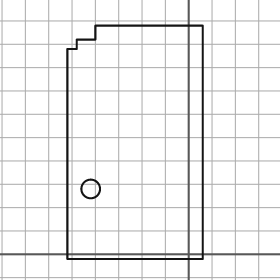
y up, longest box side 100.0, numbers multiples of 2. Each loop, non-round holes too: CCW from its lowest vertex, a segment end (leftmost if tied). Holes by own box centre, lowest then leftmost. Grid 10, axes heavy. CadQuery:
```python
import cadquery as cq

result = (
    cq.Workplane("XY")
    .moveTo(-52.0, -2.0)
    .lineTo(6.0, -2.0)
    .lineTo(6.0, 98.0)
    .lineTo(-40.0, 98.0)
    .lineTo(-40.0, 92.0)
    .lineTo(-48.0, 92.0)
    .lineTo(-48.0, 88.0)
    .lineTo(-52.0, 88.0)
    .close()
    .moveTo(-42.0, 28.0)
    .circle(4.0)
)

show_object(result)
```